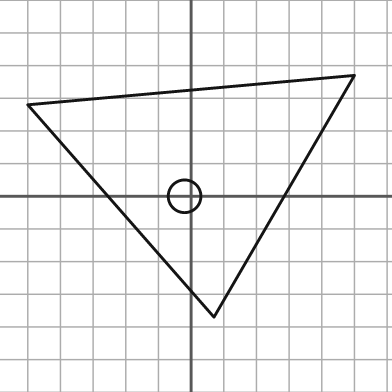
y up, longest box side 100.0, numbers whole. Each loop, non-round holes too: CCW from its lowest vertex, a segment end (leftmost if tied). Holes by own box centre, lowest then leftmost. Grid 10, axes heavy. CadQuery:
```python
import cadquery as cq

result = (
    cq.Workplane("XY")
    .moveTo(7.0, -37.0)
    .lineTo(50.0, 37.0)
    .lineTo(-50.0, 28.0)
    .close()
    .moveTo(-2.0, 0.0)
    .circle(5.0)
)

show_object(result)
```